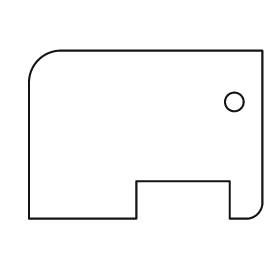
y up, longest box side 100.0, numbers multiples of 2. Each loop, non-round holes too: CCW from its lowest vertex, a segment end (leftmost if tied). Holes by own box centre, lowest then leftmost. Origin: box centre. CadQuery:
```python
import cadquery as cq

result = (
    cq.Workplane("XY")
    .moveTo(-50.0, -36.0)
    .lineTo(-4.0, -36.0)
    .lineTo(-4.0, -20.0)
    .lineTo(36.0, -20.0)
    .lineTo(36.0, -36.0)
    .lineTo(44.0, -36.0)
    .threePointArc((48.0, -34.0), (50.0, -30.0))
    .lineTo(50.0, 36.0)
    .lineTo(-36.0, 36.0)
    .threePointArc((-46.0, 32.0), (-50.0, 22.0))
    .close()
    .moveTo(38.0, 14.0)
    .circle(4.0)
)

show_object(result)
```